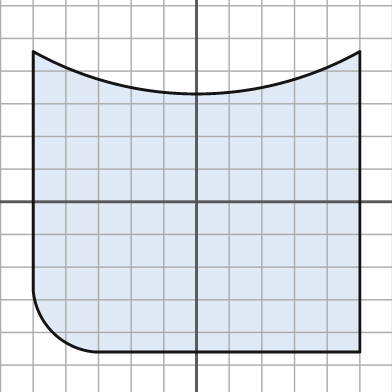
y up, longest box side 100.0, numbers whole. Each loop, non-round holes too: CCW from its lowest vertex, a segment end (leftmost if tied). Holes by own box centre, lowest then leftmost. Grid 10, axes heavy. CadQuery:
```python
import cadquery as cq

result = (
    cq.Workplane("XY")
    .moveTo(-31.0, -46.0)
    .lineTo(50.0, -46.0)
    .lineTo(50.0, 46.0)
    .threePointArc((0.0, 33.0), (-50.0, 46.0))
    .lineTo(-50.0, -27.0)
    .threePointArc((-44.0, -40.0), (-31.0, -46.0))
    .close()
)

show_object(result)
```